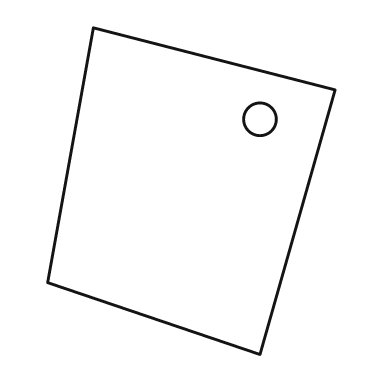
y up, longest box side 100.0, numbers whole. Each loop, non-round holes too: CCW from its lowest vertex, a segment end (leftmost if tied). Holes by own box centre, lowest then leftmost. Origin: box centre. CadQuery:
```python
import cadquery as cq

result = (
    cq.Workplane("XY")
    .moveTo(21.0, -50.0)
    .lineTo(44.0, 31.0)
    .lineTo(-30.0, 50.0)
    .lineTo(-44.0, -28.0)
    .close()
    .moveTo(21.0, 22.0)
    .circle(5.0)
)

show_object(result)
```